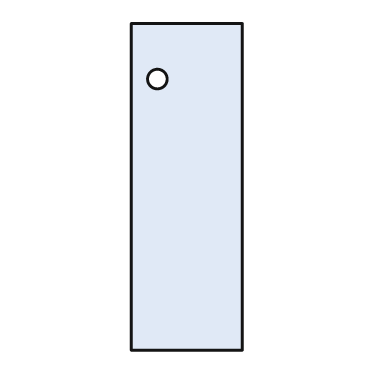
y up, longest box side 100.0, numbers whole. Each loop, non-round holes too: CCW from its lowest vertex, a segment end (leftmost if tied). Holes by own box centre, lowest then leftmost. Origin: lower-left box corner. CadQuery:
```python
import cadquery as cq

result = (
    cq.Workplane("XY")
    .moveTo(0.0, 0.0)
    .lineTo(34.0, 0.0)
    .lineTo(34.0, 100.0)
    .lineTo(0.0, 100.0)
    .close()
    .moveTo(8.0, 83.0)
    .circle(3.0)
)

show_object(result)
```